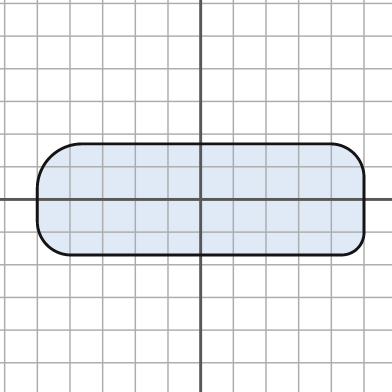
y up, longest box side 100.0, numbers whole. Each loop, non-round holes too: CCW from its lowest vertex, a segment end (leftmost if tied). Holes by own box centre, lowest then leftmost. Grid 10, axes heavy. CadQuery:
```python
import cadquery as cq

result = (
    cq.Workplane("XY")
    .moveTo(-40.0, -17.0)
    .lineTo(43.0, -17.0)
    .threePointArc((48.0, -15.0), (50.0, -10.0))
    .lineTo(50.0, 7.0)
    .threePointArc((47.0, 14.0), (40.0, 17.0))
    .lineTo(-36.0, 17.0)
    .threePointArc((-46.0, 13.0), (-50.0, 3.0))
    .lineTo(-50.0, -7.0)
    .threePointArc((-47.0, -14.0), (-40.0, -17.0))
    .close()
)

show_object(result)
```